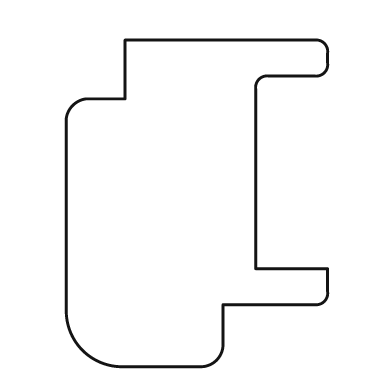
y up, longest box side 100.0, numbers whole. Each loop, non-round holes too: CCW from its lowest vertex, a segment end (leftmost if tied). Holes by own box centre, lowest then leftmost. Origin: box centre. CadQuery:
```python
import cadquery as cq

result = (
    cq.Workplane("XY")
    .moveTo(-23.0, -50.0)
    .lineTo(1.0, -50.0)
    .threePointArc((6.0, -48.0), (8.0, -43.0))
    .lineTo(8.0, -31.0)
    .lineTo(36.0, -31.0)
    .threePointArc((39.0, -30.0), (40.0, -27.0))
    .lineTo(40.0, -20.0)
    .lineTo(18.0, -20.0)
    .lineTo(18.0, 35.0)
    .threePointArc((19.0, 38.0), (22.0, 39.0))
    .lineTo(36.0, 39.0)
    .threePointArc((39.0, 40.0), (40.0, 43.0))
    .lineTo(40.0, 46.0)
    .threePointArc((39.0, 49.0), (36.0, 50.0))
    .lineTo(-22.0, 50.0)
    .lineTo(-22.0, 32.0)
    .lineTo(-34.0, 32.0)
    .threePointArc((-38.0, 30.0), (-40.0, 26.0))
    .lineTo(-40.0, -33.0)
    .threePointArc((-35.0, -45.0), (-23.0, -50.0))
    .close()
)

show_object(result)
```